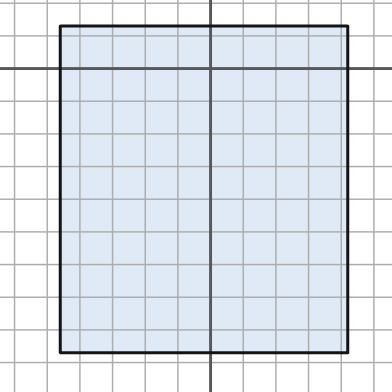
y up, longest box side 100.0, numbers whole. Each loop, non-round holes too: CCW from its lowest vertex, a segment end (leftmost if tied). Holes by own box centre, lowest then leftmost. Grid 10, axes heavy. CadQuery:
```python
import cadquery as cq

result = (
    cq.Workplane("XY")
    .moveTo(-46.0, -87.0)
    .lineTo(42.0, -87.0)
    .lineTo(42.0, 13.0)
    .lineTo(-46.0, 13.0)
    .close()
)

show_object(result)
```